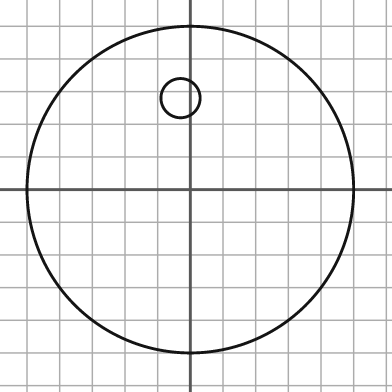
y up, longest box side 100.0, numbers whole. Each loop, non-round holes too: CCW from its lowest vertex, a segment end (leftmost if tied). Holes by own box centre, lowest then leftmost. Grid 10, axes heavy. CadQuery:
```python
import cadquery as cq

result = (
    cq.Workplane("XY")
    .moveTo(0.0, 0.0)
    .circle(50.0)
    .moveTo(-3.0, 28.0)
    .circle(6.0)
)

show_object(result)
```